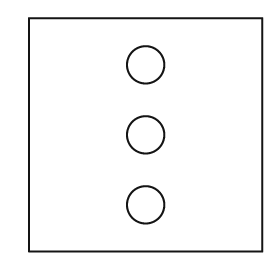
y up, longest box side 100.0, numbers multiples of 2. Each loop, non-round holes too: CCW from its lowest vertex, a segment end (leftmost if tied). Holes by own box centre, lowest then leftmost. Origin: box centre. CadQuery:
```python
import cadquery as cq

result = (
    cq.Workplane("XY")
    .moveTo(-50.0, -50.0)
    .lineTo(50.0, -50.0)
    .lineTo(50.0, 50.0)
    .lineTo(-50.0, 50.0)
    .close()
    .moveTo(0.0, -30.0)
    .circle(8.0)
    .moveTo(0.0, 0.0)
    .circle(8.0)
    .moveTo(0.0, 30.0)
    .circle(8.0)
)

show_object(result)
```